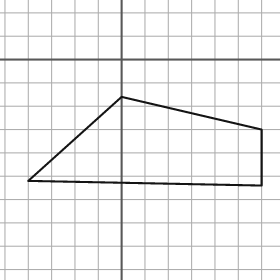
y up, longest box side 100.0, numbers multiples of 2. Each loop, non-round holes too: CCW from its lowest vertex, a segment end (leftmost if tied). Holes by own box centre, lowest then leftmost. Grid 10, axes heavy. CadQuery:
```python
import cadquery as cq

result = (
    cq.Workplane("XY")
    .moveTo(60.0, -54.0)
    .lineTo(60.0, -30.0)
    .lineTo(0.0, -16.0)
    .lineTo(-40.0, -52.0)
    .close()
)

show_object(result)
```